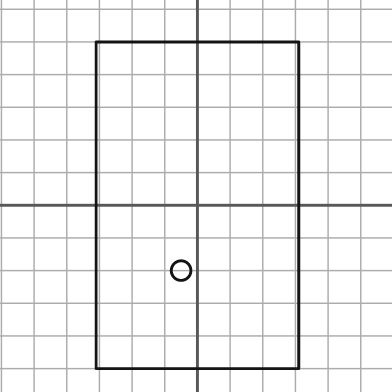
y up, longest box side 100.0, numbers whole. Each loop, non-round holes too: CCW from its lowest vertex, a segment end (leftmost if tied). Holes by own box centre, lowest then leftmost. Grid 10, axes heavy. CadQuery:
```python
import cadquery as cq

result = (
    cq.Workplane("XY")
    .moveTo(-31.0, -50.0)
    .lineTo(31.0, -50.0)
    .lineTo(31.0, 50.0)
    .lineTo(-31.0, 50.0)
    .close()
    .moveTo(-5.0, -20.0)
    .circle(3.0)
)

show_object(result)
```